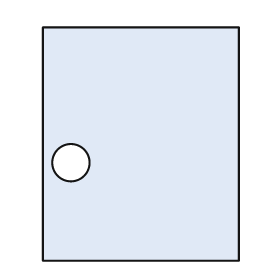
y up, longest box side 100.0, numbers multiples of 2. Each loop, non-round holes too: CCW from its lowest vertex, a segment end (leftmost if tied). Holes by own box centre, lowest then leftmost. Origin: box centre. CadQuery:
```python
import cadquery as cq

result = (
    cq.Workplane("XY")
    .moveTo(-42.0, -50.0)
    .lineTo(42.0, -50.0)
    .lineTo(42.0, 50.0)
    .lineTo(-42.0, 50.0)
    .close()
    .moveTo(-30.0, -8.0)
    .circle(8.0)
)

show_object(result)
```